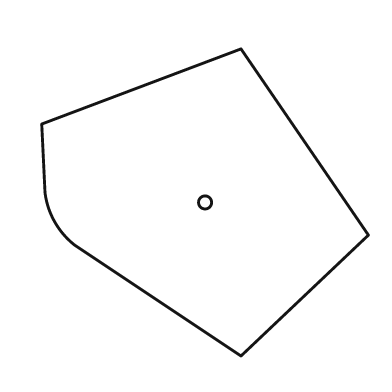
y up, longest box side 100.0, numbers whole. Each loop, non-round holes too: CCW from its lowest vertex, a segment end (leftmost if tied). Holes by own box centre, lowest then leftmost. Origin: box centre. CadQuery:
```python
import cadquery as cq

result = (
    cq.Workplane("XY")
    .moveTo(11.0, -47.0)
    .lineTo(50.0, -10.0)
    .lineTo(11.0, 47.0)
    .lineTo(-50.0, 24.0)
    .lineTo(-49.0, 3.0)
    .threePointArc((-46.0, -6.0), (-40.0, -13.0))
    .close()
    .moveTo(0.0, 0.0)
    .circle(2.0)
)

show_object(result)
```